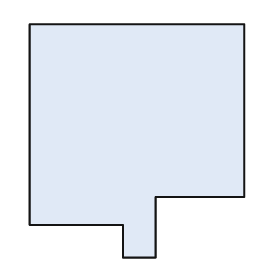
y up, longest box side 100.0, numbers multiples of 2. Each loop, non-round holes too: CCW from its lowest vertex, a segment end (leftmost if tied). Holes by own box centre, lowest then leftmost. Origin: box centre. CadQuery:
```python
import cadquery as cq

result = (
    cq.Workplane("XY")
    .moveTo(-6.0, -50.0)
    .lineTo(8.0, -50.0)
    .lineTo(8.0, -24.0)
    .lineTo(46.0, -24.0)
    .lineTo(46.0, 50.0)
    .lineTo(-46.0, 50.0)
    .lineTo(-46.0, -36.0)
    .lineTo(-6.0, -36.0)
    .close()
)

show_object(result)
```